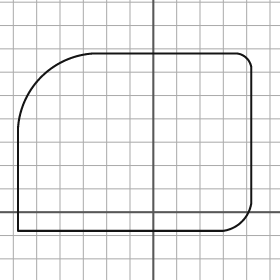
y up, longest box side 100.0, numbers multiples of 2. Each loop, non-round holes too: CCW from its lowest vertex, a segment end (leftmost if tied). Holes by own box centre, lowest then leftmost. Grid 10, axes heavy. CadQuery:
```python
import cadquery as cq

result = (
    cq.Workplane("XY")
    .moveTo(-58.0, -8.0)
    .lineTo(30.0, -8.0)
    .threePointArc((38.0, -4.0), (42.0, 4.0))
    .lineTo(42.0, 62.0)
    .threePointArc((40.0, 66.0), (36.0, 68.0))
    .lineTo(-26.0, 68.0)
    .threePointArc((-48.0, 58.0), (-58.0, 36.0))
    .close()
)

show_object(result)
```